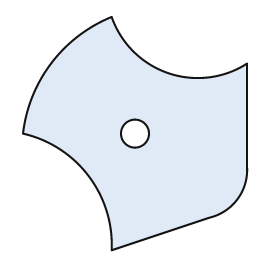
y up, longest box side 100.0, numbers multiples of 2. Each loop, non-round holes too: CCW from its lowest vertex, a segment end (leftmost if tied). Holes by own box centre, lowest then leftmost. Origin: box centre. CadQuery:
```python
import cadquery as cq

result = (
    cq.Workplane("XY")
    .moveTo(-10.0, -50.0)
    .lineTo(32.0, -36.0)
    .threePointArc((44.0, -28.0), (48.0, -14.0))
    .lineTo(48.0, 30.0)
    .threePointArc((14.0, 26.0), (-10.0, 50.0))
    .threePointArc((-36.0, 30.0), (-48.0, 0.0))
    .threePointArc((-20.0, -18.0), (-10.0, -50.0))
    .close()
    .moveTo(0.0, 0.0)
    .circle(6.0)
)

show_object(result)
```